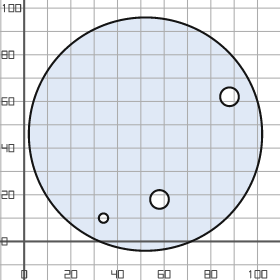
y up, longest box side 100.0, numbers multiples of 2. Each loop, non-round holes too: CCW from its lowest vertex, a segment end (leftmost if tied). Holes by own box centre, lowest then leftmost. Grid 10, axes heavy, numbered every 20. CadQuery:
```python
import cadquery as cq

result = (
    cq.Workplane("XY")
    .moveTo(52.0, 46.0)
    .circle(50.0)
    .moveTo(34.0, 10.0)
    .circle(2.0)
    .moveTo(58.0, 18.0)
    .circle(4.0)
    .moveTo(88.0, 62.0)
    .circle(4.0)
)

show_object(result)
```